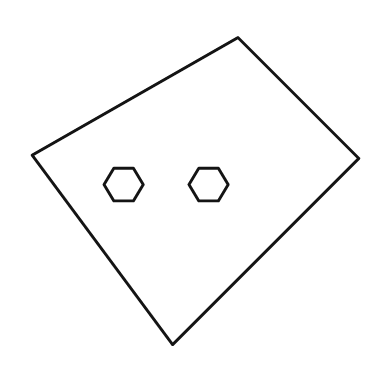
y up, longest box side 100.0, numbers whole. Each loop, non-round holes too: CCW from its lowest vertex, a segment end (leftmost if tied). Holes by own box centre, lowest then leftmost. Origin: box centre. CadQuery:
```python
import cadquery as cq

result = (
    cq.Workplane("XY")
    .moveTo(-7.0, -47.0)
    .lineTo(50.0, 10.0)
    .lineTo(13.0, 47.0)
    .lineTo(-50.0, 11.0)
    .close()
    .moveTo(-25.0, -3.0)
    .lineTo(-19.0, -3.0)
    .lineTo(-16.0, 2.0)
    .lineTo(-19.0, 7.0)
    .lineTo(-25.0, 7.0)
    .lineTo(-28.0, 2.0)
    .close()
    .moveTo(1.0, -3.0)
    .lineTo(7.0, -3.0)
    .lineTo(10.0, 2.0)
    .lineTo(7.0, 7.0)
    .lineTo(1.0, 7.0)
    .lineTo(-2.0, 2.0)
    .close()
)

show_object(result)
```